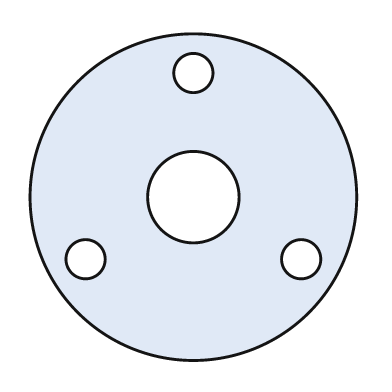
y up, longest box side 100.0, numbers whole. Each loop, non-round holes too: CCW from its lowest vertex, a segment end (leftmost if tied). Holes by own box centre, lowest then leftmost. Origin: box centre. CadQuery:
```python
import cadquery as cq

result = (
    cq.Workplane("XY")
    .moveTo(0.0, 0.0)
    .circle(50.0)
    .moveTo(-33.0, -19.0)
    .circle(6.0)
    .moveTo(33.0, -19.0)
    .circle(6.0)
    .moveTo(0.0, 0.0)
    .circle(14.0)
    .moveTo(0.0, 38.0)
    .circle(6.0)
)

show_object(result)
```